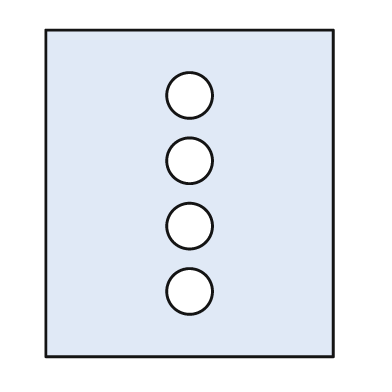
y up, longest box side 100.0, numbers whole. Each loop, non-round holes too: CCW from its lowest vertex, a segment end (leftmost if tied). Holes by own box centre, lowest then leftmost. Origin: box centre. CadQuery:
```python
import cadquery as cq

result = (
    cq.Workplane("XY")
    .moveTo(-44.0, -50.0)
    .lineTo(44.0, -50.0)
    .lineTo(44.0, 50.0)
    .lineTo(-44.0, 50.0)
    .close()
    .moveTo(0.0, -30.0)
    .circle(7.0)
    .moveTo(0.0, -10.0)
    .circle(7.0)
    .moveTo(0.0, 10.0)
    .circle(7.0)
    .moveTo(0.0, 30.0)
    .circle(7.0)
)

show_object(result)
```